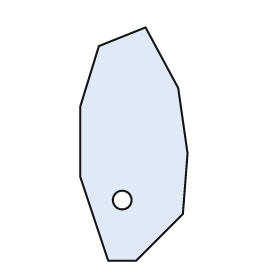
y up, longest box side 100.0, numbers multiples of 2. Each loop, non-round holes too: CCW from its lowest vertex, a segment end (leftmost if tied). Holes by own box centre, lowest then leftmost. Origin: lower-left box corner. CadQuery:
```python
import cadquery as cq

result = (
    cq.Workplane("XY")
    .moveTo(12.0, 0.0)
    .lineTo(24.0, 0.0)
    .lineTo(44.0, 20.0)
    .lineTo(46.0, 46.0)
    .lineTo(42.0, 74.0)
    .lineTo(28.0, 100.0)
    .lineTo(8.0, 92.0)
    .lineTo(0.0, 66.0)
    .lineTo(0.0, 36.0)
    .close()
    .moveTo(18.0, 26.0)
    .circle(4.0)
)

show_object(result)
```